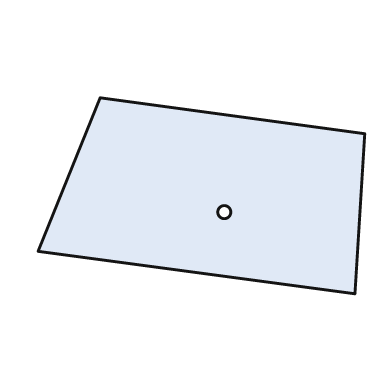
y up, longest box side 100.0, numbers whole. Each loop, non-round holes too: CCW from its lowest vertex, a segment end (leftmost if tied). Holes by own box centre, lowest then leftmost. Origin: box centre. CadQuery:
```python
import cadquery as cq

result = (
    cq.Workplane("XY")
    .moveTo(47.0, -30.0)
    .lineTo(50.0, 19.0)
    .lineTo(-31.0, 30.0)
    .lineTo(-50.0, -17.0)
    .close()
    .moveTo(7.0, -5.0)
    .circle(2.0)
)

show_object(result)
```